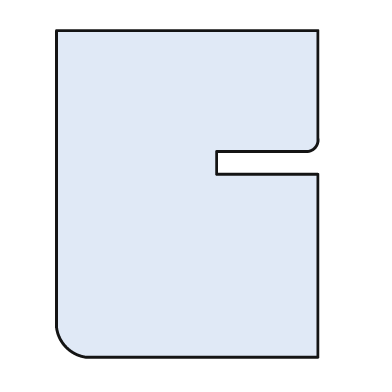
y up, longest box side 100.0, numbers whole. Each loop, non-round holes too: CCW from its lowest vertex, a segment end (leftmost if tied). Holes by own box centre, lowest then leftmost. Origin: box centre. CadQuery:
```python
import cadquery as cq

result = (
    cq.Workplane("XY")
    .moveTo(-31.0, -50.0)
    .lineTo(40.0, -50.0)
    .lineTo(40.0, 6.0)
    .lineTo(9.0, 6.0)
    .lineTo(9.0, 13.0)
    .lineTo(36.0, 13.0)
    .threePointArc((39.0, 14.0), (40.0, 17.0))
    .lineTo(40.0, 50.0)
    .lineTo(-40.0, 50.0)
    .lineTo(-40.0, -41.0)
    .threePointArc((-37.0, -47.0), (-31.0, -50.0))
    .close()
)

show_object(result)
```